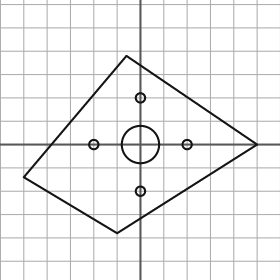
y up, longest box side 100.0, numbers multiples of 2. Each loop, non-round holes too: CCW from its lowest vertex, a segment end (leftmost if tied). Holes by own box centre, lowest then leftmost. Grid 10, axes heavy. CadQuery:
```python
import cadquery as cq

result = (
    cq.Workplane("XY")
    .moveTo(-10.0, -38.0)
    .lineTo(50.0, 0.0)
    .lineTo(-6.0, 38.0)
    .lineTo(-50.0, -14.0)
    .close()
    .moveTo(0.0, -20.0)
    .circle(2.0)
    .moveTo(-20.0, 0.0)
    .circle(2.0)
    .moveTo(0.0, 0.0)
    .circle(8.0)
    .moveTo(20.0, 0.0)
    .circle(2.0)
    .moveTo(0.0, 20.0)
    .circle(2.0)
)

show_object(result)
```